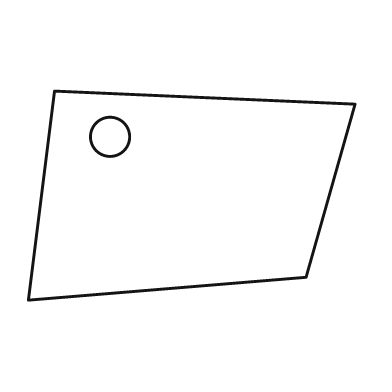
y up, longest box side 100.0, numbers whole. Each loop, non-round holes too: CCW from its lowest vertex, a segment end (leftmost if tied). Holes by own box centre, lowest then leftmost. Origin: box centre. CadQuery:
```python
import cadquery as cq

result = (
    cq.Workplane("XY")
    .moveTo(-50.0, -32.0)
    .lineTo(35.0, -25.0)
    .lineTo(50.0, 28.0)
    .lineTo(-42.0, 32.0)
    .close()
    .moveTo(-25.0, 18.0)
    .circle(6.0)
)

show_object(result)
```